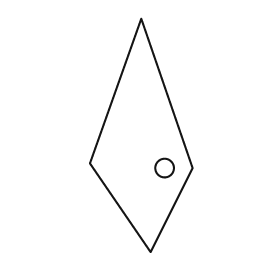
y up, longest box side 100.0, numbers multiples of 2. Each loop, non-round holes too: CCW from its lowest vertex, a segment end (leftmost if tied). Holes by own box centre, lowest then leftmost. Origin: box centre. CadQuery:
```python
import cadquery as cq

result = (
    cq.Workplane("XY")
    .moveTo(4.0, -50.0)
    .lineTo(22.0, -14.0)
    .lineTo(0.0, 50.0)
    .lineTo(-22.0, -12.0)
    .close()
    .moveTo(10.0, -14.0)
    .circle(4.0)
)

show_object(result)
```